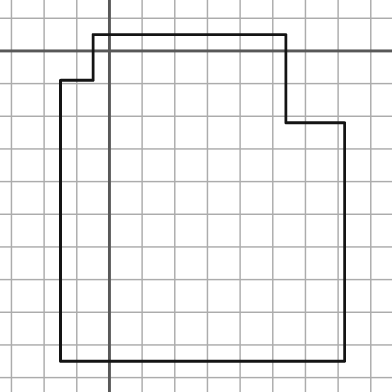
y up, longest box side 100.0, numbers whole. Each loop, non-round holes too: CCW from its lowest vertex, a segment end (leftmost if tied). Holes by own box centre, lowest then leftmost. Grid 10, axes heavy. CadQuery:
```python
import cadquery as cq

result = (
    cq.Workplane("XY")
    .moveTo(-15.0, -95.0)
    .lineTo(72.0, -95.0)
    .lineTo(72.0, -22.0)
    .lineTo(54.0, -22.0)
    .lineTo(54.0, 5.0)
    .lineTo(-5.0, 5.0)
    .lineTo(-5.0, -9.0)
    .lineTo(-15.0, -9.0)
    .close()
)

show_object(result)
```